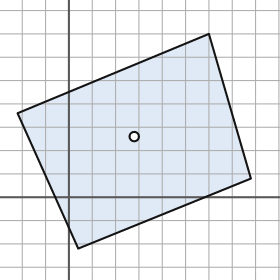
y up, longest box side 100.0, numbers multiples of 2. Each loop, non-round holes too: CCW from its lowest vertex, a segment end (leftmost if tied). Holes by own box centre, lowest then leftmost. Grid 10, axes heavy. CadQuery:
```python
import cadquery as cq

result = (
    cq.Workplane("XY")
    .moveTo(4.0, -22.0)
    .lineTo(78.0, 8.0)
    .lineTo(60.0, 70.0)
    .lineTo(-22.0, 36.0)
    .close()
    .moveTo(28.0, 26.0)
    .circle(2.0)
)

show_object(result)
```